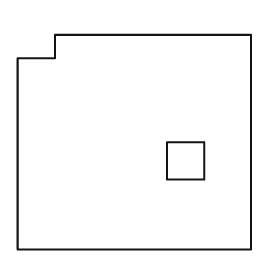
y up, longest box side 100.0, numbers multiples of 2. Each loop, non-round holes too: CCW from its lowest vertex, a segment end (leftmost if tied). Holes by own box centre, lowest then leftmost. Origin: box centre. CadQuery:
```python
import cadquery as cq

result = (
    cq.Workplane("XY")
    .moveTo(-50.0, -46.0)
    .lineTo(50.0, -46.0)
    .lineTo(50.0, 46.0)
    .lineTo(-34.0, 46.0)
    .lineTo(-34.0, 36.0)
    .lineTo(-50.0, 36.0)
    .close()
    .moveTo(14.0, -16.0)
    .lineTo(30.0, -16.0)
    .lineTo(30.0, 0.0)
    .lineTo(14.0, 0.0)
    .close()
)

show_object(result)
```